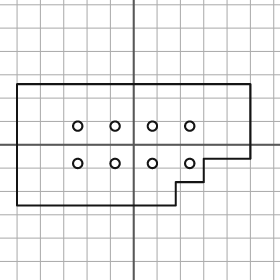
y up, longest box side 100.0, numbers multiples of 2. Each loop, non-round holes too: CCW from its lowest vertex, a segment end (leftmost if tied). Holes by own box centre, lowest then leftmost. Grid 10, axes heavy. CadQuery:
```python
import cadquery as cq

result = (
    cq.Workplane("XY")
    .moveTo(-50.0, -26.0)
    .lineTo(18.0, -26.0)
    .lineTo(18.0, -16.0)
    .lineTo(30.0, -16.0)
    .lineTo(30.0, -6.0)
    .lineTo(50.0, -6.0)
    .lineTo(50.0, 26.0)
    .lineTo(-50.0, 26.0)
    .close()
    .moveTo(-24.0, -8.0)
    .circle(2.0)
    .moveTo(-8.0, -8.0)
    .circle(2.0)
    .moveTo(8.0, -8.0)
    .circle(2.0)
    .moveTo(24.0, -8.0)
    .circle(2.0)
    .moveTo(-24.0, 8.0)
    .circle(2.0)
    .moveTo(-8.0, 8.0)
    .circle(2.0)
    .moveTo(8.0, 8.0)
    .circle(2.0)
    .moveTo(24.0, 8.0)
    .circle(2.0)
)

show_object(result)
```